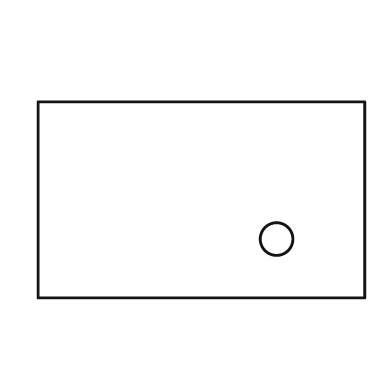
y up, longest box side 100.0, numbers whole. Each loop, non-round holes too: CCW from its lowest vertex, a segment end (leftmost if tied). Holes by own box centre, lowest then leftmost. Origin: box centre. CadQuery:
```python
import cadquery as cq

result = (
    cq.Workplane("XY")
    .moveTo(-50.0, -30.0)
    .lineTo(50.0, -30.0)
    .lineTo(50.0, 30.0)
    .lineTo(-50.0, 30.0)
    .close()
    .moveTo(23.0, -12.0)
    .circle(5.0)
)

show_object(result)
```